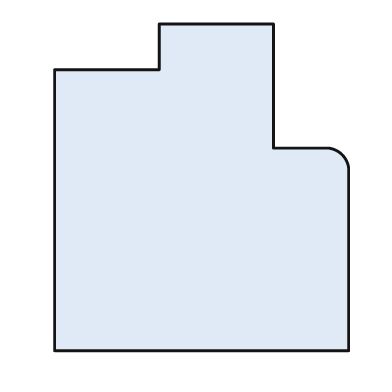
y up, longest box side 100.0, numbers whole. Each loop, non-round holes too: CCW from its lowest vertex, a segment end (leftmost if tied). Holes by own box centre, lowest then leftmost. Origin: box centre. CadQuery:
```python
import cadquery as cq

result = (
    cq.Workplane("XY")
    .moveTo(-45.0, -50.0)
    .lineTo(45.0, -50.0)
    .lineTo(45.0, 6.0)
    .threePointArc((43.0, 10.0), (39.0, 12.0))
    .lineTo(22.0, 12.0)
    .lineTo(22.0, 50.0)
    .lineTo(-13.0, 50.0)
    .lineTo(-13.0, 36.0)
    .lineTo(-45.0, 36.0)
    .close()
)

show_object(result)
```